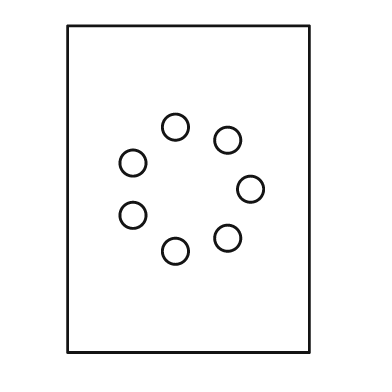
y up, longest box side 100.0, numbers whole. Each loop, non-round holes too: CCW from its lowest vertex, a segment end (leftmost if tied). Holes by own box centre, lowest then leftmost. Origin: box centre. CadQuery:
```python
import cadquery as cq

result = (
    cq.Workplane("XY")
    .moveTo(-37.0, -50.0)
    .lineTo(37.0, -50.0)
    .lineTo(37.0, 50.0)
    .lineTo(-37.0, 50.0)
    .close()
    .moveTo(-4.0, -19.0)
    .circle(4.0)
    .moveTo(12.0, -15.0)
    .circle(4.0)
    .moveTo(-17.0, -8.0)
    .circle(4.0)
    .moveTo(19.0, 0.0)
    .circle(4.0)
    .moveTo(-17.0, 8.0)
    .circle(4.0)
    .moveTo(12.0, 15.0)
    .circle(4.0)
    .moveTo(-4.0, 19.0)
    .circle(4.0)
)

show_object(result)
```